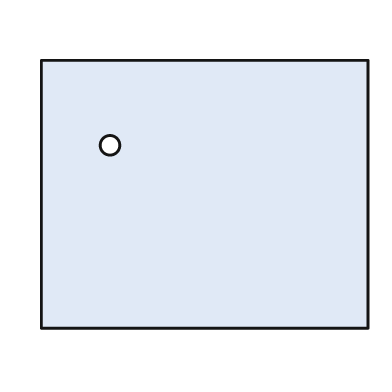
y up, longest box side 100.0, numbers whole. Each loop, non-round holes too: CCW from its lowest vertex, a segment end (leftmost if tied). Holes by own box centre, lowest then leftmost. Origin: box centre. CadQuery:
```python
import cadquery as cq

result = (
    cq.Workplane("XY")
    .moveTo(-50.0, -41.0)
    .lineTo(50.0, -41.0)
    .lineTo(50.0, 41.0)
    .lineTo(-50.0, 41.0)
    .close()
    .moveTo(-29.0, 15.0)
    .circle(3.0)
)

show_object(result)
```